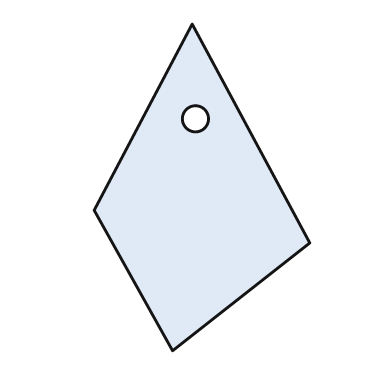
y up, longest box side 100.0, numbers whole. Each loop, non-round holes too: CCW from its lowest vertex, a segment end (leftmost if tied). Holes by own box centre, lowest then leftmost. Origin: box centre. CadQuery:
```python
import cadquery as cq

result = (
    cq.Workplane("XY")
    .moveTo(-9.0, -50.0)
    .lineTo(33.0, -17.0)
    .lineTo(-3.0, 50.0)
    .lineTo(-33.0, -7.0)
    .close()
    .moveTo(-2.0, 21.0)
    .circle(4.0)
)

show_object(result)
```